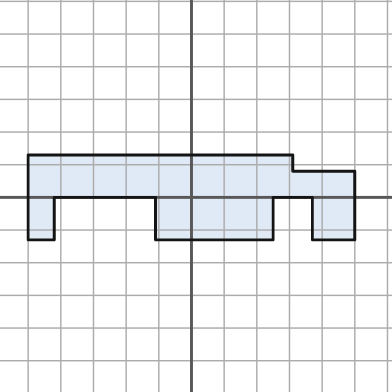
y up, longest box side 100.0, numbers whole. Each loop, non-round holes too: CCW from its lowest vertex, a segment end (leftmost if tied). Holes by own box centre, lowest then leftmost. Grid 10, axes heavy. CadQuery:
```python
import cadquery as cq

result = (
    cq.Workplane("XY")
    .moveTo(-50.0, -13.0)
    .lineTo(-42.0, -13.0)
    .lineTo(-42.0, 0.0)
    .lineTo(-11.0, 0.0)
    .lineTo(-11.0, -13.0)
    .lineTo(25.0, -13.0)
    .lineTo(25.0, 0.0)
    .lineTo(37.0, 0.0)
    .lineTo(37.0, -13.0)
    .lineTo(50.0, -13.0)
    .lineTo(50.0, 8.0)
    .lineTo(31.0, 8.0)
    .lineTo(31.0, 13.0)
    .lineTo(-50.0, 13.0)
    .close()
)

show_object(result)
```